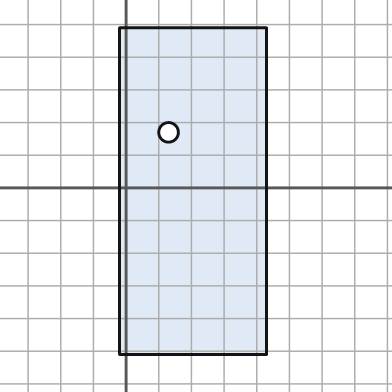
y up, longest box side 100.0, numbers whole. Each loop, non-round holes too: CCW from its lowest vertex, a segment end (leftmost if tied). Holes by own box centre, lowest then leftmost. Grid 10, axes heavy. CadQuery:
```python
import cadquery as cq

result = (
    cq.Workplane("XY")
    .moveTo(-2.0, -51.0)
    .lineTo(43.0, -51.0)
    .lineTo(43.0, 49.0)
    .lineTo(-2.0, 49.0)
    .close()
    .moveTo(13.0, 17.0)
    .circle(3.0)
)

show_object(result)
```